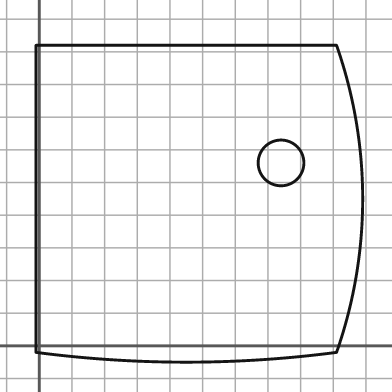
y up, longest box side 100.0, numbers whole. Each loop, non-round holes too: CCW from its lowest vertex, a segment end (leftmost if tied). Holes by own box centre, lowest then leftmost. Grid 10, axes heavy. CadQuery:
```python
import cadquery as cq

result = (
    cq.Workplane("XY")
    .moveTo(-1.0, -2.0)
    .threePointArc((45.0, -5.0), (91.0, -2.0))
    .threePointArc((99.0, 45.0), (91.0, 92.0))
    .lineTo(-1.0, 92.0)
    .close()
    .moveTo(74.0, 56.0)
    .circle(7.0)
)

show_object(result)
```